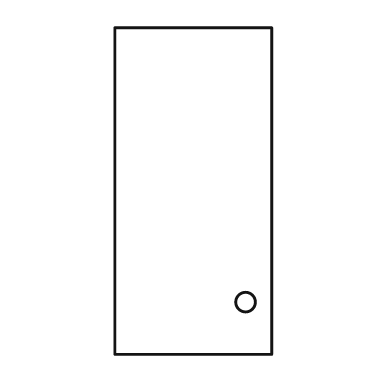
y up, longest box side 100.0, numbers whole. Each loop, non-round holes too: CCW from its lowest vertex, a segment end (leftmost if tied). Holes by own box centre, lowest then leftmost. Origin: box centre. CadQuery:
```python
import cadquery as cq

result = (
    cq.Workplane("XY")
    .moveTo(-24.0, -50.0)
    .lineTo(24.0, -50.0)
    .lineTo(24.0, 50.0)
    .lineTo(-24.0, 50.0)
    .close()
    .moveTo(16.0, -34.0)
    .circle(3.0)
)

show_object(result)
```